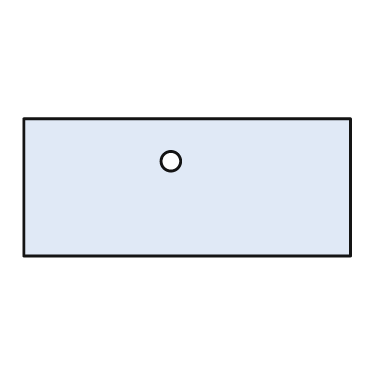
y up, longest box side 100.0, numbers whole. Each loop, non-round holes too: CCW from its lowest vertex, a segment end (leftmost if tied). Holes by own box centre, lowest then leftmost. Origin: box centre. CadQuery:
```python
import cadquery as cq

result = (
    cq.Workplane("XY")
    .moveTo(-50.0, -21.0)
    .lineTo(50.0, -21.0)
    .lineTo(50.0, 21.0)
    .lineTo(-50.0, 21.0)
    .close()
    .moveTo(-5.0, 8.0)
    .circle(3.0)
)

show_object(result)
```